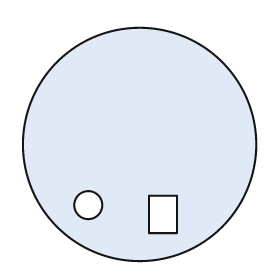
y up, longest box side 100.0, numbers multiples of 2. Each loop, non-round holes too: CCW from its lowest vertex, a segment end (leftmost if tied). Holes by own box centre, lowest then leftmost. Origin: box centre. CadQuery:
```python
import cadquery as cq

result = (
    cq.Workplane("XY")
    .moveTo(0.0, 0.0)
    .circle(50.0)
    .moveTo(4.0, -38.0)
    .lineTo(16.0, -38.0)
    .lineTo(16.0, -22.0)
    .lineTo(4.0, -22.0)
    .close()
    .moveTo(-22.0, -26.0)
    .circle(6.0)
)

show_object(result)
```